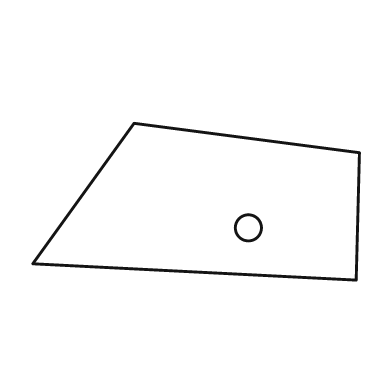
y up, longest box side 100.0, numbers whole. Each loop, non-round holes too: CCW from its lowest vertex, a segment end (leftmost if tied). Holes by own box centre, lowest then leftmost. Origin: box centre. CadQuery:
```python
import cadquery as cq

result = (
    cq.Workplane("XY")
    .moveTo(49.0, -24.0)
    .lineTo(50.0, 15.0)
    .lineTo(-19.0, 24.0)
    .lineTo(-50.0, -19.0)
    .close()
    .moveTo(16.0, -8.0)
    .circle(4.0)
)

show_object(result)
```